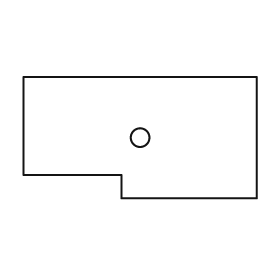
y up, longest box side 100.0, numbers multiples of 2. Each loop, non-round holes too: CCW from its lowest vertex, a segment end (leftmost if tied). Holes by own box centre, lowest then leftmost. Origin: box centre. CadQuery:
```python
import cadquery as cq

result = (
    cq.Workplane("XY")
    .moveTo(-8.0, -26.0)
    .lineTo(50.0, -26.0)
    .lineTo(50.0, 26.0)
    .lineTo(-50.0, 26.0)
    .lineTo(-50.0, -16.0)
    .lineTo(-8.0, -16.0)
    .close()
    .moveTo(0.0, 0.0)
    .circle(4.0)
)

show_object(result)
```